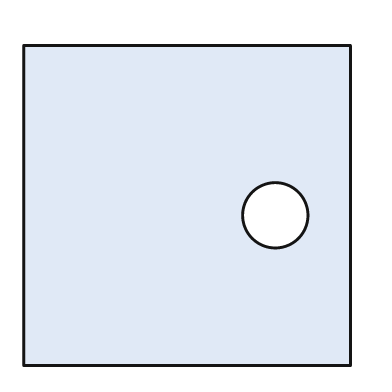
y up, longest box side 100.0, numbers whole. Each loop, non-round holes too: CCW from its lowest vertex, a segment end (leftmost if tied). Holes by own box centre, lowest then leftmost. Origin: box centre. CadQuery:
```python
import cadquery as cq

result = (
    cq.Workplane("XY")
    .moveTo(-50.0, -49.0)
    .lineTo(50.0, -49.0)
    .lineTo(50.0, 49.0)
    .lineTo(-50.0, 49.0)
    .close()
    .moveTo(27.0, -3.0)
    .circle(10.0)
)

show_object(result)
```